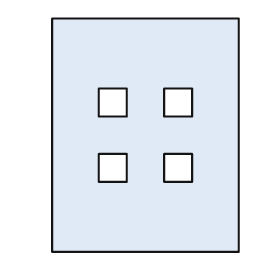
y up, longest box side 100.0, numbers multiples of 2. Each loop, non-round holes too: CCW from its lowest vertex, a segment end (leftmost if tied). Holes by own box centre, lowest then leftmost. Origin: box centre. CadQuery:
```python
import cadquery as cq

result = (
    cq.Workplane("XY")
    .moveTo(-40.0, -50.0)
    .lineTo(40.0, -50.0)
    .lineTo(40.0, 50.0)
    .lineTo(-40.0, 50.0)
    .close()
    .moveTo(-20.0, -20.0)
    .lineTo(-8.0, -20.0)
    .lineTo(-8.0, -8.0)
    .lineTo(-20.0, -8.0)
    .close()
    .moveTo(8.0, -20.0)
    .lineTo(20.0, -20.0)
    .lineTo(20.0, -8.0)
    .lineTo(8.0, -8.0)
    .close()
    .moveTo(-20.0, 8.0)
    .lineTo(-8.0, 8.0)
    .lineTo(-8.0, 20.0)
    .lineTo(-20.0, 20.0)
    .close()
    .moveTo(8.0, 8.0)
    .lineTo(20.0, 8.0)
    .lineTo(20.0, 20.0)
    .lineTo(8.0, 20.0)
    .close()
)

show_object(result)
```